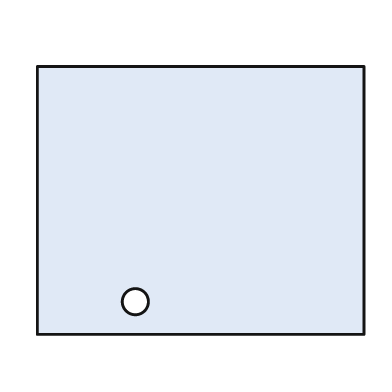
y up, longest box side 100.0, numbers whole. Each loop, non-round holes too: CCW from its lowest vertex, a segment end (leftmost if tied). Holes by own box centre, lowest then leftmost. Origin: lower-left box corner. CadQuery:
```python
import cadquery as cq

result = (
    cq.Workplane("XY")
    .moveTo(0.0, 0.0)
    .lineTo(100.0, 0.0)
    .lineTo(100.0, 82.0)
    .lineTo(0.0, 82.0)
    .close()
    .moveTo(30.0, 10.0)
    .circle(4.0)
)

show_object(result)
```